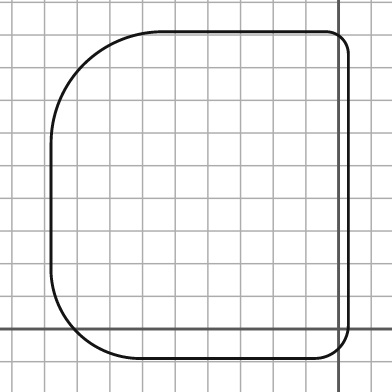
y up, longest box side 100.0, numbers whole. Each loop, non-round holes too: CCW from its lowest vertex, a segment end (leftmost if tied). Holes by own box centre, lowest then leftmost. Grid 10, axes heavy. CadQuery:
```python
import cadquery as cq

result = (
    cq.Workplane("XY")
    .moveTo(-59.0, -9.0)
    .lineTo(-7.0, -9.0)
    .threePointArc((0.0, -6.0), (3.0, 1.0))
    .lineTo(3.0, 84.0)
    .threePointArc((1.0, 89.0), (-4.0, 91.0))
    .lineTo(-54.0, 91.0)
    .threePointArc((-78.0, 81.0), (-88.0, 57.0))
    .lineTo(-88.0, 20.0)
    .threePointArc((-80.0, -1.0), (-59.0, -9.0))
    .close()
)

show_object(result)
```